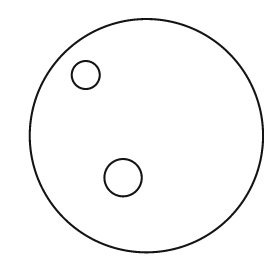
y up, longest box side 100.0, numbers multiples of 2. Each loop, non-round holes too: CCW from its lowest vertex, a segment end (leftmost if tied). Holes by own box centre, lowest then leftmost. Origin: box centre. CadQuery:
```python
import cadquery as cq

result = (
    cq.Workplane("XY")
    .moveTo(0.0, 0.0)
    .circle(50.0)
    .moveTo(-10.0, -18.0)
    .circle(8.0)
    .moveTo(-26.0, 26.0)
    .circle(6.0)
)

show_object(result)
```